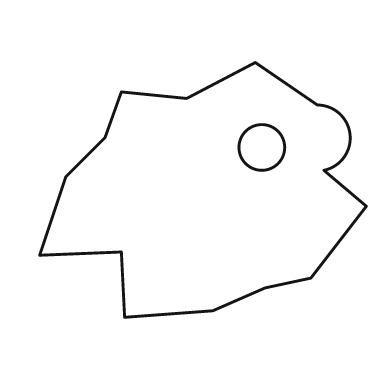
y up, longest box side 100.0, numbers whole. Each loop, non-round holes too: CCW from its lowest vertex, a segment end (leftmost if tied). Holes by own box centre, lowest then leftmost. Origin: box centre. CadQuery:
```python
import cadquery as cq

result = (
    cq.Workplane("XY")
    .moveTo(-24.0, -39.0)
    .lineTo(3.0, -37.0)
    .lineTo(19.0, -30.0)
    .lineTo(33.0, -27.0)
    .lineTo(50.0, -5.0)
    .lineTo(37.0, 6.0)
    .threePointArc((45.0, 17.0), (35.0, 26.0))
    .lineTo(16.0, 39.0)
    .lineTo(-5.0, 28.0)
    .lineTo(-25.0, 30.0)
    .lineTo(-30.0, 16.0)
    .lineTo(-42.0, 4.0)
    .lineTo(-50.0, -20.0)
    .lineTo(-25.0, -19.0)
    .close()
    .moveTo(18.0, 13.0)
    .circle(7.0)
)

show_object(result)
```